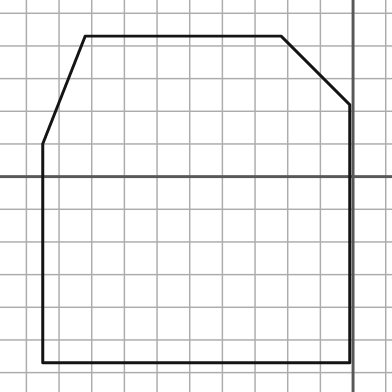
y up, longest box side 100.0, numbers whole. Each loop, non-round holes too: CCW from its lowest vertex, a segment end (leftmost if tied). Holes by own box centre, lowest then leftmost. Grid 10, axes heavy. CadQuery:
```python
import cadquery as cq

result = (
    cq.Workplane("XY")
    .moveTo(-95.0, -57.0)
    .lineTo(-1.0, -57.0)
    .lineTo(-1.0, 22.0)
    .lineTo(-22.0, 43.0)
    .lineTo(-82.0, 43.0)
    .lineTo(-95.0, 10.0)
    .close()
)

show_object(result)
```